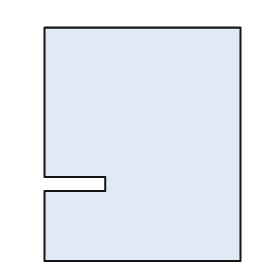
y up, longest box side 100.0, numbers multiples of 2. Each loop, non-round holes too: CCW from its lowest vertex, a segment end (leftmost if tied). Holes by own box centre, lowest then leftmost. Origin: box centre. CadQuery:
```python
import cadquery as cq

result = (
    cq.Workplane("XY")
    .moveTo(-42.0, -50.0)
    .lineTo(42.0, -50.0)
    .lineTo(42.0, 50.0)
    .lineTo(-42.0, 50.0)
    .lineTo(-42.0, -14.0)
    .lineTo(-16.0, -14.0)
    .lineTo(-16.0, -20.0)
    .lineTo(-42.0, -20.0)
    .close()
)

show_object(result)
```